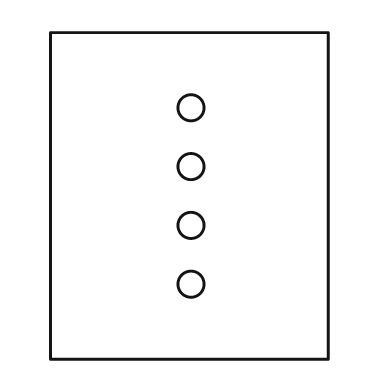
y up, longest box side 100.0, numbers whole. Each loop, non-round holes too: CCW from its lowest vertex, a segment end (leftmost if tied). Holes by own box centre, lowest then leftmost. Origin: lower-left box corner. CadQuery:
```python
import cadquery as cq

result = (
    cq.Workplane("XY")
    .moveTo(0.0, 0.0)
    .lineTo(85.0, 0.0)
    .lineTo(85.0, 100.0)
    .lineTo(0.0, 100.0)
    .close()
    .moveTo(43.0, 23.0)
    .circle(4.0)
    .moveTo(43.0, 41.0)
    .circle(4.0)
    .moveTo(43.0, 59.0)
    .circle(4.0)
    .moveTo(43.0, 77.0)
    .circle(4.0)
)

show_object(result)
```